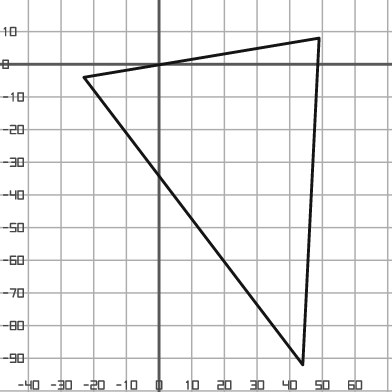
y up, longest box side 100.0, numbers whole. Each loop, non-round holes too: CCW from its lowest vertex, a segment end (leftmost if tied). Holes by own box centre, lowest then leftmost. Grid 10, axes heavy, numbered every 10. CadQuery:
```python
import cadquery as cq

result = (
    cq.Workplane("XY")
    .moveTo(44.0, -92.0)
    .lineTo(49.0, 8.0)
    .lineTo(-23.0, -4.0)
    .close()
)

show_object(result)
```